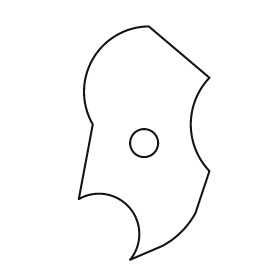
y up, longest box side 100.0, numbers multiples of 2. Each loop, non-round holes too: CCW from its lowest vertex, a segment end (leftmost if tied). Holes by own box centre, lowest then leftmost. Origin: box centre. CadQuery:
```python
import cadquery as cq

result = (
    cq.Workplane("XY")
    .moveTo(-6.0, -50.0)
    .lineTo(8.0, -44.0)
    .threePointArc((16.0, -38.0), (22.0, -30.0))
    .lineTo(28.0, -12.0)
    .threePointArc((20.0, 8.0), (28.0, 28.0))
    .lineTo(2.0, 50.0)
    .threePointArc((-22.0, 36.0), (-22.0, 8.0))
    .lineTo(-28.0, -24.0)
    .threePointArc((-6.0, -28.0), (-6.0, -50.0))
    .close()
    .moveTo(0.0, 0.0)
    .circle(6.0)
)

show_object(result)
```